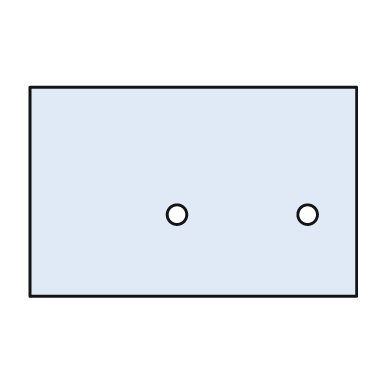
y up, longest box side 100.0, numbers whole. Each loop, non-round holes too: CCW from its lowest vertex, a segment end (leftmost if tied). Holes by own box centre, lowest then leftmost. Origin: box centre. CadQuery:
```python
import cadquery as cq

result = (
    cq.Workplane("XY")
    .moveTo(-50.0, -32.0)
    .lineTo(50.0, -32.0)
    .lineTo(50.0, 32.0)
    .lineTo(-50.0, 32.0)
    .close()
    .moveTo(-5.0, -7.0)
    .circle(3.0)
    .moveTo(35.0, -7.0)
    .circle(3.0)
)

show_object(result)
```